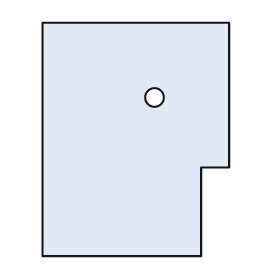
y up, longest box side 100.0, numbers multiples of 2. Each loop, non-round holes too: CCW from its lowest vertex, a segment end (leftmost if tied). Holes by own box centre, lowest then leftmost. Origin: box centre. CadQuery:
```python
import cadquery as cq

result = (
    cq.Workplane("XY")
    .moveTo(-40.0, -50.0)
    .lineTo(28.0, -50.0)
    .lineTo(28.0, -12.0)
    .lineTo(40.0, -12.0)
    .lineTo(40.0, 50.0)
    .lineTo(-40.0, 50.0)
    .close()
    .moveTo(8.0, 18.0)
    .circle(4.0)
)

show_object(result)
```